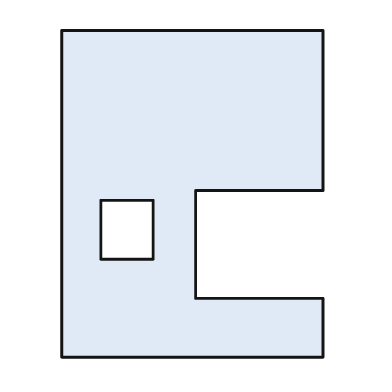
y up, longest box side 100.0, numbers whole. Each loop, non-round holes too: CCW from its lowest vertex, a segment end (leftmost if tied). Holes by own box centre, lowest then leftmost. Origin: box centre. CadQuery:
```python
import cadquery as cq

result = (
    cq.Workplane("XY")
    .moveTo(-40.0, -50.0)
    .lineTo(40.0, -50.0)
    .lineTo(40.0, -32.0)
    .lineTo(1.0, -32.0)
    .lineTo(1.0, 1.0)
    .lineTo(40.0, 1.0)
    .lineTo(40.0, 50.0)
    .lineTo(-40.0, 50.0)
    .close()
    .moveTo(-28.0, -20.0)
    .lineTo(-12.0, -20.0)
    .lineTo(-12.0, -2.0)
    .lineTo(-28.0, -2.0)
    .close()
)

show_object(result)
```